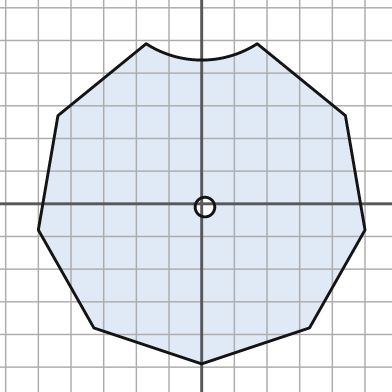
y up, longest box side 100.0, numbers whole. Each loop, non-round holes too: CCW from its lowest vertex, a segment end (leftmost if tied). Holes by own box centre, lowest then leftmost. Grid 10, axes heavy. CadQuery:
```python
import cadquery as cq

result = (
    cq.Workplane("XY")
    .moveTo(0.0, -49.0)
    .lineTo(33.0, -38.0)
    .lineTo(50.0, -8.0)
    .lineTo(44.0, 27.0)
    .lineTo(17.0, 49.0)
    .threePointArc((0.0, 44.0), (-17.0, 49.0))
    .lineTo(-44.0, 27.0)
    .lineTo(-50.0, -8.0)
    .lineTo(-33.0, -38.0)
    .close()
    .moveTo(1.0, -1.0)
    .circle(3.0)
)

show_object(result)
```